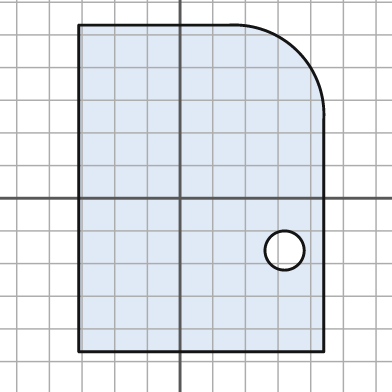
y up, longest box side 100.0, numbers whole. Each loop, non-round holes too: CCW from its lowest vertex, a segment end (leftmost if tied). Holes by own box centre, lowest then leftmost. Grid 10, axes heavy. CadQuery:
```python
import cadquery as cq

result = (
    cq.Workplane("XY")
    .moveTo(-31.0, -47.0)
    .lineTo(44.0, -47.0)
    .lineTo(44.0, 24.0)
    .threePointArc((36.0, 45.0), (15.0, 53.0))
    .lineTo(-31.0, 53.0)
    .close()
    .moveTo(32.0, -16.0)
    .circle(6.0)
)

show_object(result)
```